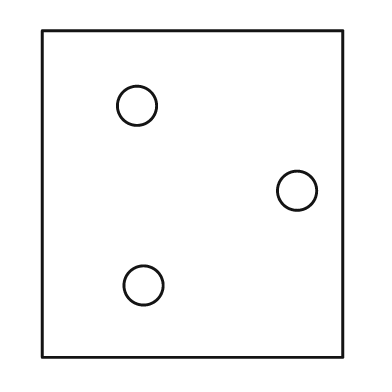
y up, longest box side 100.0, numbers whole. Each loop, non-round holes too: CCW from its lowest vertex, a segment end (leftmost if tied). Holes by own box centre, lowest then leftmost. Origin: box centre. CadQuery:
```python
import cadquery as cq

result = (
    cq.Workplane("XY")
    .moveTo(-46.0, -50.0)
    .lineTo(46.0, -50.0)
    .lineTo(46.0, 50.0)
    .lineTo(-46.0, 50.0)
    .close()
    .moveTo(-15.0, -28.0)
    .circle(6.0)
    .moveTo(32.0, 1.0)
    .circle(6.0)
    .moveTo(-17.0, 27.0)
    .circle(6.0)
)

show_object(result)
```